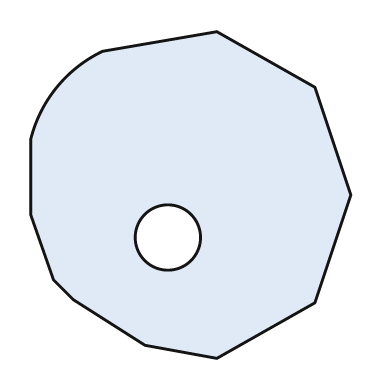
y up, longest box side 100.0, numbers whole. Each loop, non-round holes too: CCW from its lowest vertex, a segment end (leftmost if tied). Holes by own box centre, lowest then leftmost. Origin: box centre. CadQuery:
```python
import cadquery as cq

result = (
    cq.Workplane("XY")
    .moveTo(8.0, -50.0)
    .lineTo(38.0, -33.0)
    .lineTo(49.0, 0.0)
    .lineTo(38.0, 33.0)
    .lineTo(8.0, 50.0)
    .lineTo(-27.0, 44.0)
    .threePointArc((-41.0, 33.0), (-49.0, 17.0))
    .lineTo(-49.0, -6.0)
    .lineTo(-42.0, -26.0)
    .lineTo(-36.0, -32.0)
    .lineTo(-14.0, -46.0)
    .close()
    .moveTo(-7.0, -13.0)
    .circle(10.0)
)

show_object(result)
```